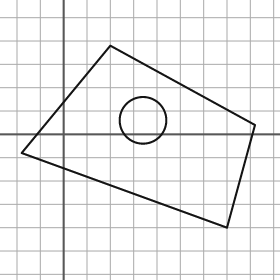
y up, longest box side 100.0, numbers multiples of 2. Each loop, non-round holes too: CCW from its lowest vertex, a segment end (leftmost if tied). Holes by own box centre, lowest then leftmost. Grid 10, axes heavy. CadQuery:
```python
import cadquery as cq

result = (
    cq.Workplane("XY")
    .moveTo(70.0, -40.0)
    .lineTo(82.0, 4.0)
    .lineTo(20.0, 38.0)
    .lineTo(-18.0, -8.0)
    .close()
    .moveTo(34.0, 6.0)
    .circle(10.0)
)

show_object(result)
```